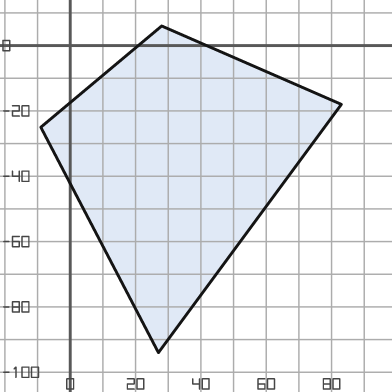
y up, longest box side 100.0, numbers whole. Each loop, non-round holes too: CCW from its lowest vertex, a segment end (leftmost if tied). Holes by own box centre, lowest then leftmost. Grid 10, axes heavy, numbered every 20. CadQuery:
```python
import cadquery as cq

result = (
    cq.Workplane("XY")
    .moveTo(27.0, -94.0)
    .lineTo(83.0, -18.0)
    .lineTo(28.0, 6.0)
    .lineTo(-9.0, -25.0)
    .close()
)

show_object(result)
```